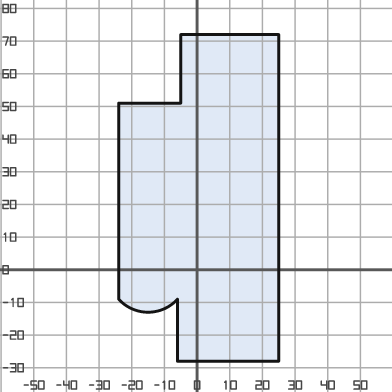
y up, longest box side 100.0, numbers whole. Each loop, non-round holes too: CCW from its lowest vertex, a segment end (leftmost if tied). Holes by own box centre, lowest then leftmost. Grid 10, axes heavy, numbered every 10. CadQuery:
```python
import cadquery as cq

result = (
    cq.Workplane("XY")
    .moveTo(-6.0, -28.0)
    .lineTo(25.0, -28.0)
    .lineTo(25.0, 72.0)
    .lineTo(-5.0, 72.0)
    .lineTo(-5.0, 51.0)
    .lineTo(-24.0, 51.0)
    .lineTo(-24.0, -9.0)
    .threePointArc((-15.0, -13.0), (-6.0, -9.0))
    .close()
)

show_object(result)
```